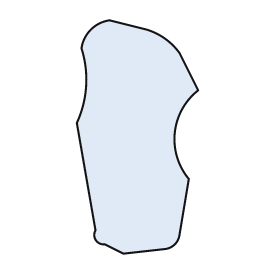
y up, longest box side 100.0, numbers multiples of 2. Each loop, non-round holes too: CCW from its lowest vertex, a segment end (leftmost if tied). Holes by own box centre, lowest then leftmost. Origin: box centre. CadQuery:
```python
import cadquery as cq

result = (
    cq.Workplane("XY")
    .moveTo(-6.0, -50.0)
    .lineTo(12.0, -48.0)
    .threePointArc((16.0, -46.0), (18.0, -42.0))
    .lineTo(22.0, -18.0)
    .threePointArc((16.0, 2.0), (26.0, 20.0))
    .lineTo(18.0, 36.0)
    .threePointArc((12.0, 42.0), (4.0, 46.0))
    .lineTo(-12.0, 50.0)
    .threePointArc((-20.0, 46.0), (-24.0, 38.0))
    .threePointArc((-22.0, 22.0), (-26.0, 6.0))
    .lineTo(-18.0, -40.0)
    .threePointArc((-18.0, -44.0), (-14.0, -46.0))
    .close()
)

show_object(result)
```